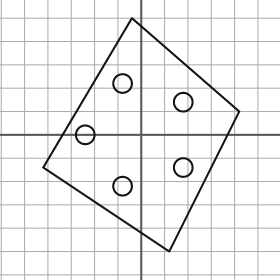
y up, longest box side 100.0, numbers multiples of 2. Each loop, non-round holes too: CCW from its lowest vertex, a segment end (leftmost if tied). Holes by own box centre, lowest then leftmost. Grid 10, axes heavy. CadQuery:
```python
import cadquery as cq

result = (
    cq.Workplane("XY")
    .moveTo(12.0, -50.0)
    .lineTo(42.0, 10.0)
    .lineTo(-4.0, 50.0)
    .lineTo(-42.0, -14.0)
    .close()
    .moveTo(-8.0, -22.0)
    .circle(4.0)
    .moveTo(18.0, -14.0)
    .circle(4.0)
    .moveTo(-24.0, 0.0)
    .circle(4.0)
    .moveTo(18.0, 14.0)
    .circle(4.0)
    .moveTo(-8.0, 22.0)
    .circle(4.0)
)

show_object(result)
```